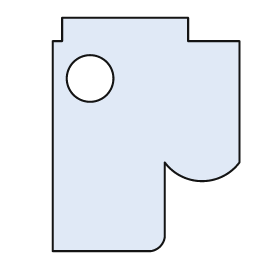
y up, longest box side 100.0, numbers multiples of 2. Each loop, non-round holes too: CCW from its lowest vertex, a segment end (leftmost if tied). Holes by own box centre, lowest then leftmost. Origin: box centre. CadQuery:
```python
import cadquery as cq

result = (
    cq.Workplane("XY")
    .moveTo(-40.0, -50.0)
    .lineTo(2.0, -50.0)
    .threePointArc((6.0, -48.0), (8.0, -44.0))
    .lineTo(8.0, -12.0)
    .threePointArc((24.0, -20.0), (40.0, -12.0))
    .lineTo(40.0, 40.0)
    .lineTo(18.0, 40.0)
    .lineTo(18.0, 50.0)
    .lineTo(-36.0, 50.0)
    .lineTo(-36.0, 40.0)
    .lineTo(-40.0, 40.0)
    .close()
    .moveTo(-24.0, 24.0)
    .circle(10.0)
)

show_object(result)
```